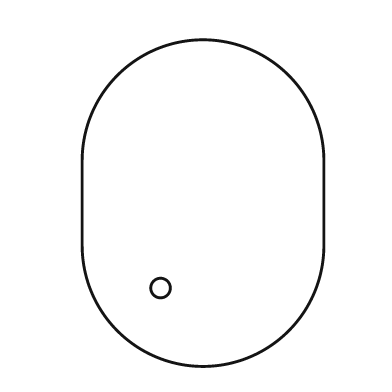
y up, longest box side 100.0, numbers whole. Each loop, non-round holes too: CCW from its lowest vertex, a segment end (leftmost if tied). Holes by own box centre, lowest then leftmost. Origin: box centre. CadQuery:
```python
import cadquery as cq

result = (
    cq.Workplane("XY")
    .moveTo(-37.0, -13.0)
    .threePointArc((0.0, -50.0), (37.0, -13.0))
    .lineTo(37.0, 13.0)
    .threePointArc((0.0, 50.0), (-37.0, 13.0))
    .close()
    .moveTo(-13.0, -26.0)
    .circle(3.0)
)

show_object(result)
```